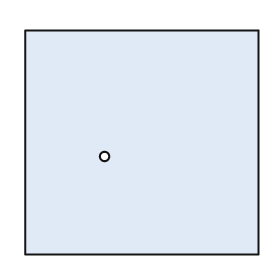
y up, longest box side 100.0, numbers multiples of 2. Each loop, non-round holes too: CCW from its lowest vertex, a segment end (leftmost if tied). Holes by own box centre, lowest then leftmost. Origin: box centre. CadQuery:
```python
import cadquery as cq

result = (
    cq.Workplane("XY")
    .moveTo(-50.0, -48.0)
    .lineTo(50.0, -48.0)
    .lineTo(50.0, 48.0)
    .lineTo(-50.0, 48.0)
    .close()
    .moveTo(-16.0, -6.0)
    .circle(2.0)
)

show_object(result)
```